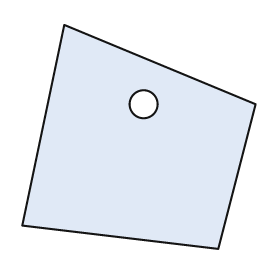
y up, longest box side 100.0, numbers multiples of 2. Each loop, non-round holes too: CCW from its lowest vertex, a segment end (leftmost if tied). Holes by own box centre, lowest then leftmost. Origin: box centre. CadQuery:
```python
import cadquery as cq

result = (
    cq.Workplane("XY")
    .moveTo(34.0, -48.0)
    .lineTo(50.0, 14.0)
    .lineTo(-32.0, 48.0)
    .lineTo(-50.0, -38.0)
    .close()
    .moveTo(2.0, 14.0)
    .circle(6.0)
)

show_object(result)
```